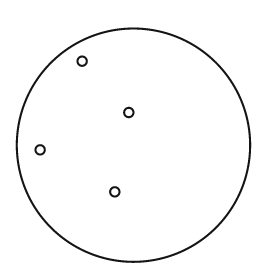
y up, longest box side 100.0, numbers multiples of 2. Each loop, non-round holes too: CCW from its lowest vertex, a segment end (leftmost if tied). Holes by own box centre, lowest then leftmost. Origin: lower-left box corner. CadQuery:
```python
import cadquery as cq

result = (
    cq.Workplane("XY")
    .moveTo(50.0, 50.0)
    .circle(50.0)
    .moveTo(42.0, 30.0)
    .circle(2.0)
    .moveTo(10.0, 48.0)
    .circle(2.0)
    .moveTo(48.0, 64.0)
    .circle(2.0)
    .moveTo(28.0, 86.0)
    .circle(2.0)
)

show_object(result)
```